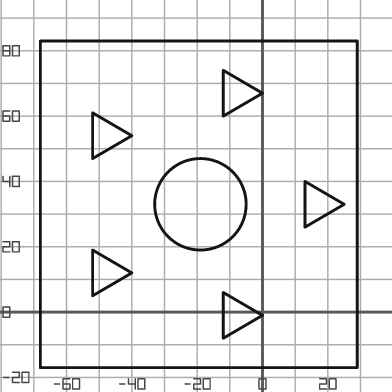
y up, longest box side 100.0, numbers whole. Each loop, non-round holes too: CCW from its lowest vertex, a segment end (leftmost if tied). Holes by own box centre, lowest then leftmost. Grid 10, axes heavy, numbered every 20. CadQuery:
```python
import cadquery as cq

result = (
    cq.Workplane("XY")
    .moveTo(-68.0, -17.0)
    .lineTo(29.0, -17.0)
    .lineTo(29.0, 83.0)
    .lineTo(-68.0, 83.0)
    .close()
    .moveTo(-12.0, -8.0)
    .lineTo(0.0, -1.0)
    .lineTo(-12.0, 6.0)
    .close()
    .moveTo(-52.0, 5.0)
    .lineTo(-40.0, 12.0)
    .lineTo(-52.0, 19.0)
    .close()
    .moveTo(-19.0, 33.0)
    .circle(14.0)
    .moveTo(13.0, 26.0)
    .lineTo(25.0, 33.0)
    .lineTo(13.0, 40.0)
    .close()
    .moveTo(-52.0, 47.0)
    .lineTo(-40.0, 54.0)
    .lineTo(-52.0, 61.0)
    .close()
    .moveTo(-12.0, 60.0)
    .lineTo(0.0, 67.0)
    .lineTo(-12.0, 74.0)
    .close()
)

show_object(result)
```